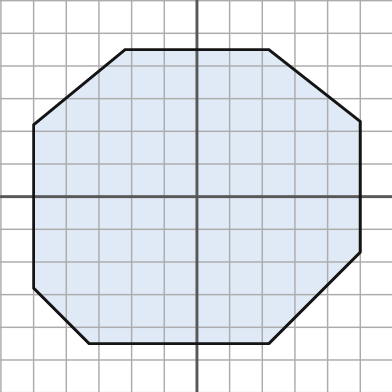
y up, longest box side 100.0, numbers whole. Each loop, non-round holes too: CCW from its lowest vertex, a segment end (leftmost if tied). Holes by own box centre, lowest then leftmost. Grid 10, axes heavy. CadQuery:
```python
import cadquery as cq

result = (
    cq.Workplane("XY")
    .moveTo(-33.0, -45.0)
    .lineTo(22.0, -45.0)
    .lineTo(50.0, -17.0)
    .lineTo(50.0, 23.0)
    .lineTo(22.0, 45.0)
    .lineTo(-22.0, 45.0)
    .lineTo(-50.0, 22.0)
    .lineTo(-50.0, -28.0)
    .close()
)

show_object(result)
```